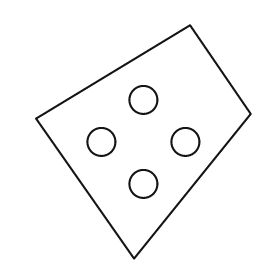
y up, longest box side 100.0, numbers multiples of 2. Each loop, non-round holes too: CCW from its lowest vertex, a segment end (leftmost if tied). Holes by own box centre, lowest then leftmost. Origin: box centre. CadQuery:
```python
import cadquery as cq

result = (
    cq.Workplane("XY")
    .moveTo(-4.0, -50.0)
    .lineTo(46.0, 12.0)
    .lineTo(20.0, 50.0)
    .lineTo(-46.0, 10.0)
    .close()
    .moveTo(0.0, -18.0)
    .circle(6.0)
    .moveTo(-18.0, 0.0)
    .circle(6.0)
    .moveTo(18.0, 0.0)
    .circle(6.0)
    .moveTo(0.0, 18.0)
    .circle(6.0)
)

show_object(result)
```